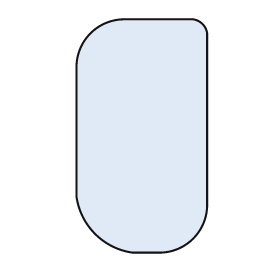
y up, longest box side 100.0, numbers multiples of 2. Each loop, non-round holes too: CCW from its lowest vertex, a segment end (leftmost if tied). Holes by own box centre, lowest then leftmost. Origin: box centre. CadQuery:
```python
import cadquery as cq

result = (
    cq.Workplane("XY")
    .moveTo(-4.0, -50.0)
    .lineTo(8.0, -50.0)
    .threePointArc((22.0, -44.0), (28.0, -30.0))
    .lineTo(28.0, 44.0)
    .threePointArc((26.0, 48.0), (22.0, 50.0))
    .lineTo(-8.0, 50.0)
    .threePointArc((-22.0, 44.0), (-28.0, 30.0))
    .lineTo(-28.0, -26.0)
    .threePointArc((-20.0, -42.0), (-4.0, -50.0))
    .close()
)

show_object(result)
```